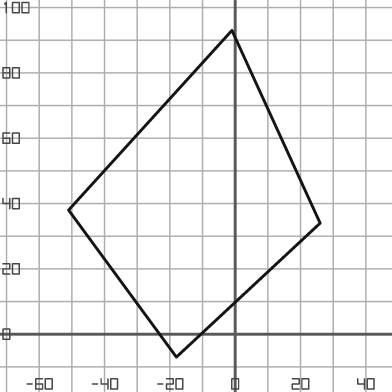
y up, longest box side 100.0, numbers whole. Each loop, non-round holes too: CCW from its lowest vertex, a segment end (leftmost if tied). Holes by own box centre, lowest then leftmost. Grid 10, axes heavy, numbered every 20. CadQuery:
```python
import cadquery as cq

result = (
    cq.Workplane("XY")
    .moveTo(-18.0, -7.0)
    .lineTo(26.0, 34.0)
    .lineTo(-1.0, 93.0)
    .lineTo(-51.0, 38.0)
    .close()
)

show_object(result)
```